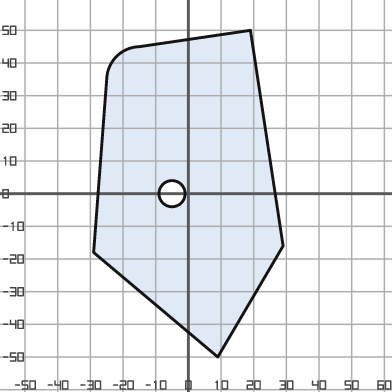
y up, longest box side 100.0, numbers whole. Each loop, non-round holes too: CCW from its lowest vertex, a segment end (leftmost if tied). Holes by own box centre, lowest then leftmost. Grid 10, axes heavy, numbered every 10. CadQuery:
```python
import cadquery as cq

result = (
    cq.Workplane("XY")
    .moveTo(9.0, -50.0)
    .lineTo(29.0, -16.0)
    .lineTo(19.0, 50.0)
    .lineTo(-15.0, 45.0)
    .threePointArc((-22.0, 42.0), (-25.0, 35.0))
    .lineTo(-29.0, -18.0)
    .close()
    .moveTo(-5.0, 0.0)
    .circle(4.0)
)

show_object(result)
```